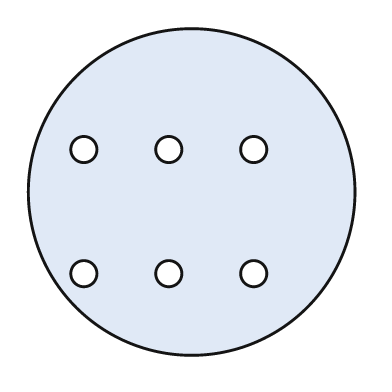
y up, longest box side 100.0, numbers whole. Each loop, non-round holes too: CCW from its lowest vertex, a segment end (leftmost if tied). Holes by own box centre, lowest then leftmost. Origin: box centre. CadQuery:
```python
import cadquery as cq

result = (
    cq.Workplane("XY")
    .moveTo(0.0, 0.0)
    .circle(50.0)
    .moveTo(-33.0, -25.0)
    .circle(4.0)
    .moveTo(-7.0, -25.0)
    .circle(4.0)
    .moveTo(19.0, -25.0)
    .circle(4.0)
    .moveTo(-33.0, 13.0)
    .circle(4.0)
    .moveTo(-7.0, 13.0)
    .circle(4.0)
    .moveTo(19.0, 13.0)
    .circle(4.0)
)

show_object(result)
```